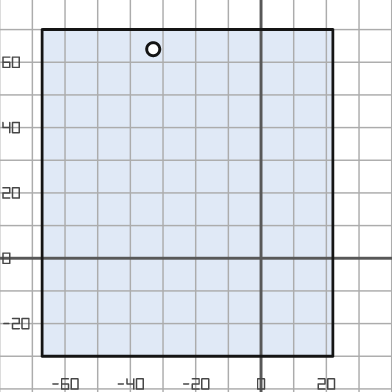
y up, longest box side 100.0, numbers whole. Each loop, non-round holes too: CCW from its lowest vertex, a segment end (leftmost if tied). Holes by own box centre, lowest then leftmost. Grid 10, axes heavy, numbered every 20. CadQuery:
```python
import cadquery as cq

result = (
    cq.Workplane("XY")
    .moveTo(-67.0, -30.0)
    .lineTo(22.0, -30.0)
    .lineTo(22.0, 70.0)
    .lineTo(-67.0, 70.0)
    .close()
    .moveTo(-33.0, 64.0)
    .circle(2.0)
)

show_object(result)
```